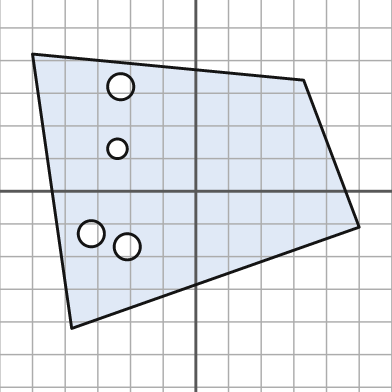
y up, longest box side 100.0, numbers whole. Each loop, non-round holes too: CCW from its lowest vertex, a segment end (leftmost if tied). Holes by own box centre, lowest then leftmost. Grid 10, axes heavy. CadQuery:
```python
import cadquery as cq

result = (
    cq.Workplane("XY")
    .moveTo(-38.0, -42.0)
    .lineTo(50.0, -11.0)
    .lineTo(33.0, 34.0)
    .lineTo(-50.0, 42.0)
    .close()
    .moveTo(-21.0, -17.0)
    .circle(4.0)
    .moveTo(-32.0, -13.0)
    .circle(4.0)
    .moveTo(-24.0, 13.0)
    .circle(3.0)
    .moveTo(-23.0, 32.0)
    .circle(4.0)
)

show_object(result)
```